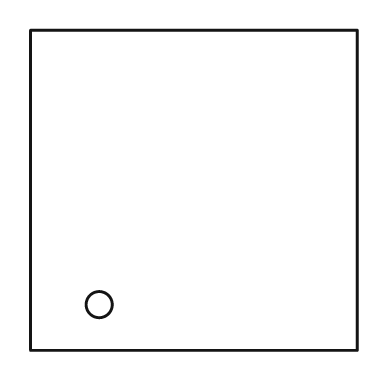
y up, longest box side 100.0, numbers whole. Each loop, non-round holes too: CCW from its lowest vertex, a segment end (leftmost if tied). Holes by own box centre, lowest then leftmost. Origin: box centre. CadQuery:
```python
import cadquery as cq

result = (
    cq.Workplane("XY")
    .moveTo(-50.0, -49.0)
    .lineTo(50.0, -49.0)
    .lineTo(50.0, 49.0)
    .lineTo(-50.0, 49.0)
    .close()
    .moveTo(-29.0, -35.0)
    .circle(4.0)
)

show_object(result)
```